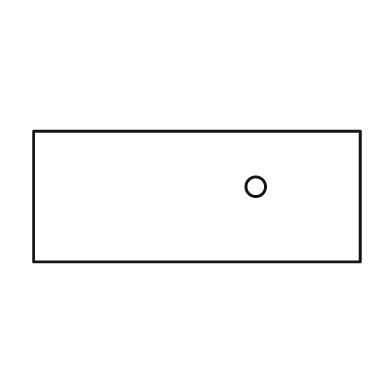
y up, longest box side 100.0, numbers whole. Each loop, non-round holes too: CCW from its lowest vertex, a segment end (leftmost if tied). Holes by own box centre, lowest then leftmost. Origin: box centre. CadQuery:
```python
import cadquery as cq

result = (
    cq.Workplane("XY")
    .moveTo(-50.0, -20.0)
    .lineTo(50.0, -20.0)
    .lineTo(50.0, 20.0)
    .lineTo(-50.0, 20.0)
    .close()
    .moveTo(18.0, 3.0)
    .circle(3.0)
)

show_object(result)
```